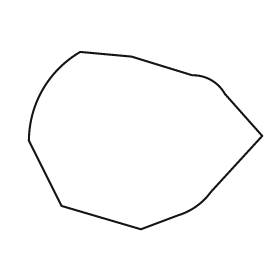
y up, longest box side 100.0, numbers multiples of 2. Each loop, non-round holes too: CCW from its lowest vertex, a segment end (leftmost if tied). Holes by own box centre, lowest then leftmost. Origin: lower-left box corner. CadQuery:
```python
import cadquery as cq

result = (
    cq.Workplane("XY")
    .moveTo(48.0, 0.0)
    .lineTo(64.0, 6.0)
    .threePointArc((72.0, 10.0), (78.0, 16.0))
    .lineTo(100.0, 40.0)
    .lineTo(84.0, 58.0)
    .threePointArc((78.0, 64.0), (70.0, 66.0))
    .lineTo(44.0, 74.0)
    .lineTo(22.0, 76.0)
    .threePointArc((6.0, 60.0), (0.0, 38.0))
    .lineTo(14.0, 10.0)
    .close()
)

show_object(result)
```